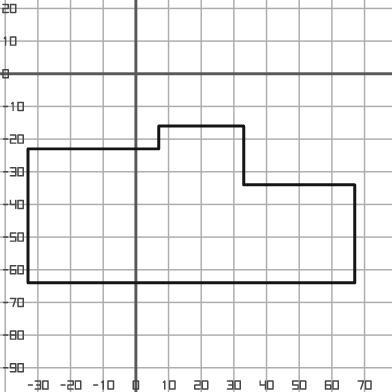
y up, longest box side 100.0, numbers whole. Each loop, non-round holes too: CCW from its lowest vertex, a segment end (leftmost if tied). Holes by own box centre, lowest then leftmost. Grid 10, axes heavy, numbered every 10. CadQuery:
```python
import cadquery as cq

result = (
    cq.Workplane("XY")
    .moveTo(-33.0, -64.0)
    .lineTo(67.0, -64.0)
    .lineTo(67.0, -34.0)
    .lineTo(33.0, -34.0)
    .lineTo(33.0, -16.0)
    .lineTo(7.0, -16.0)
    .lineTo(7.0, -23.0)
    .lineTo(-33.0, -23.0)
    .close()
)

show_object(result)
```